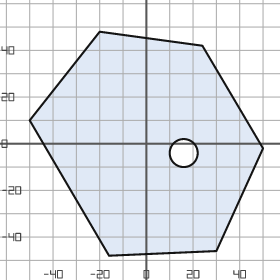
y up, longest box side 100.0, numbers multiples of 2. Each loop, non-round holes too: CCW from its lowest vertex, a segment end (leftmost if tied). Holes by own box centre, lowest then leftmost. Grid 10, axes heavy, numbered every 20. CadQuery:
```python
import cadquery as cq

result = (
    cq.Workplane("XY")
    .moveTo(-16.0, -48.0)
    .lineTo(30.0, -46.0)
    .lineTo(50.0, -2.0)
    .lineTo(24.0, 42.0)
    .lineTo(-20.0, 48.0)
    .lineTo(-50.0, 10.0)
    .close()
    .moveTo(16.0, -4.0)
    .circle(6.0)
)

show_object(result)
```